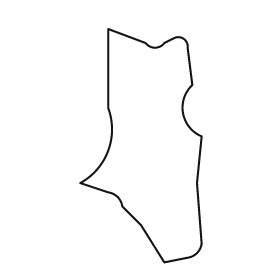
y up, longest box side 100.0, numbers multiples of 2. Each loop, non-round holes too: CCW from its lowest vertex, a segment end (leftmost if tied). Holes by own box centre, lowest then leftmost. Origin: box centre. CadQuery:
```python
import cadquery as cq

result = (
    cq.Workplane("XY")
    .moveTo(10.0, -50.0)
    .lineTo(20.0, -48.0)
    .threePointArc((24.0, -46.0), (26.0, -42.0))
    .lineTo(24.0, -16.0)
    .lineTo(26.0, 4.0)
    .threePointArc((18.0, 14.0), (22.0, 26.0))
    .lineTo(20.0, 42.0)
    .threePointArc((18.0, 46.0), (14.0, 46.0))
    .lineTo(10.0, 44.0)
    .threePointArc((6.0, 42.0), (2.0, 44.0))
    .lineTo(-14.0, 50.0)
    .lineTo(-14.0, 16.0)
    .threePointArc((-14.0, -2.0), (-26.0, -16.0))
    .lineTo(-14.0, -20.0)
    .threePointArc((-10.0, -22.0), (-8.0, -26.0))
    .lineTo(0.0, -34.0)
    .close()
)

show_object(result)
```